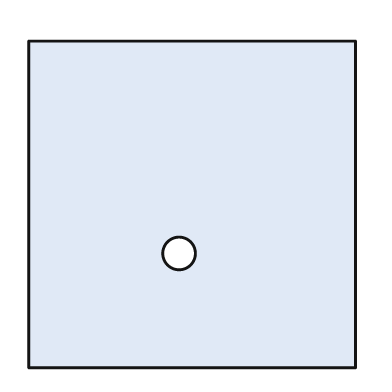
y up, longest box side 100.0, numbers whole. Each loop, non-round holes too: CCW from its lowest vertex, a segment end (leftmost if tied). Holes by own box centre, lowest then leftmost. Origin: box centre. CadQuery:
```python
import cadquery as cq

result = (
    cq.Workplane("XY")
    .moveTo(-50.0, -50.0)
    .lineTo(50.0, -50.0)
    .lineTo(50.0, 50.0)
    .lineTo(-50.0, 50.0)
    .close()
    .moveTo(-4.0, -15.0)
    .circle(5.0)
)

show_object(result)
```